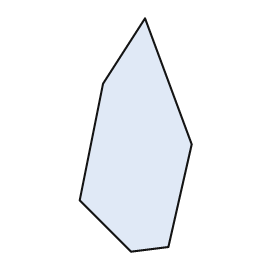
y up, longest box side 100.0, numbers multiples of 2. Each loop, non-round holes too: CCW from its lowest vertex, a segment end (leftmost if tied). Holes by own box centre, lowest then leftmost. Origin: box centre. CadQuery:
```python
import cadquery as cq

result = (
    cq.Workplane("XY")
    .moveTo(-2.0, -50.0)
    .lineTo(14.0, -48.0)
    .lineTo(24.0, -4.0)
    .lineTo(4.0, 50.0)
    .lineTo(-14.0, 22.0)
    .lineTo(-24.0, -28.0)
    .close()
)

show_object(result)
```